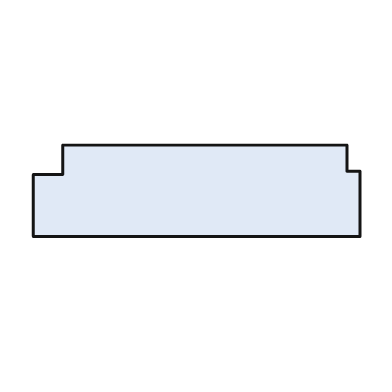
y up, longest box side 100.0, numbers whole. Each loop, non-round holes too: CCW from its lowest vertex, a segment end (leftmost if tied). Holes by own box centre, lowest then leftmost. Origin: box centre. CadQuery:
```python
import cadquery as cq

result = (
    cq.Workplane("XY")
    .moveTo(-50.0, -14.0)
    .lineTo(50.0, -14.0)
    .lineTo(50.0, 6.0)
    .lineTo(46.0, 6.0)
    .lineTo(46.0, 14.0)
    .lineTo(-41.0, 14.0)
    .lineTo(-41.0, 5.0)
    .lineTo(-50.0, 5.0)
    .close()
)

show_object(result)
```